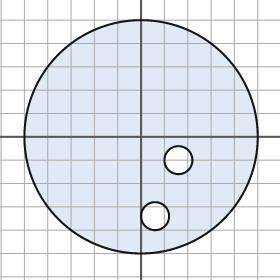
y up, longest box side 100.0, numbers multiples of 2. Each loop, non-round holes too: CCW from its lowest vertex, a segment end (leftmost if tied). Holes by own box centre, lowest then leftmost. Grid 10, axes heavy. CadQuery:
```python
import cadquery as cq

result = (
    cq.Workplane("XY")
    .moveTo(0.0, 0.0)
    .circle(50.0)
    .moveTo(6.0, -34.0)
    .circle(6.0)
    .moveTo(16.0, -10.0)
    .circle(6.0)
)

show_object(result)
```